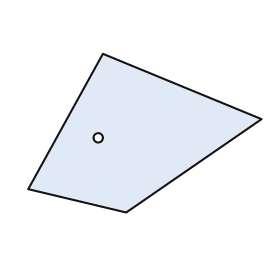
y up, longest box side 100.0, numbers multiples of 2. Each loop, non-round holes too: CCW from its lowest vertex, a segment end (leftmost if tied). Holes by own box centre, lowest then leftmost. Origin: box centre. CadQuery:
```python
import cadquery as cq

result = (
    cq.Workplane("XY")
    .moveTo(-8.0, -34.0)
    .lineTo(50.0, 6.0)
    .lineTo(-18.0, 34.0)
    .lineTo(-50.0, -24.0)
    .close()
    .moveTo(-20.0, -2.0)
    .circle(2.0)
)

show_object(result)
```